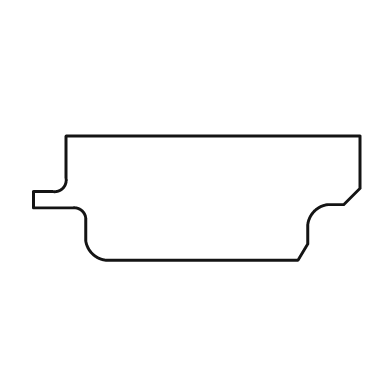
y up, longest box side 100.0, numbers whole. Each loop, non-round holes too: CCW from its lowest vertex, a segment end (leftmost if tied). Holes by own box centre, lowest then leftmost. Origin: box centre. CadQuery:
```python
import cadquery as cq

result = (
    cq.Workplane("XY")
    .moveTo(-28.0, -19.0)
    .lineTo(31.0, -19.0)
    .lineTo(34.0, -14.0)
    .lineTo(34.0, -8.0)
    .threePointArc((36.0, -4.0), (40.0, -2.0))
    .lineTo(45.0, -2.0)
    .lineTo(50.0, 3.0)
    .lineTo(50.0, 19.0)
    .lineTo(-40.0, 19.0)
    .lineTo(-40.0, 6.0)
    .threePointArc((-41.0, 3.0), (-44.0, 2.0))
    .lineTo(-50.0, 2.0)
    .lineTo(-50.0, -3.0)
    .lineTo(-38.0, -3.0)
    .threePointArc((-35.0, -4.0), (-34.0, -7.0))
    .lineTo(-34.0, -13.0)
    .threePointArc((-32.0, -17.0), (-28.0, -19.0))
    .close()
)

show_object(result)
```